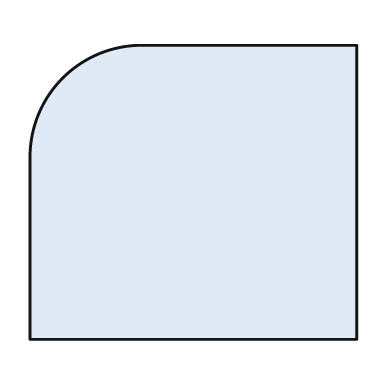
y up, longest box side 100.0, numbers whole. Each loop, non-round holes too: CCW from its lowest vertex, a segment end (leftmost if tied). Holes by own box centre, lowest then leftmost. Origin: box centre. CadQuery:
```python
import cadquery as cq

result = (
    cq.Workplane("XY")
    .moveTo(-50.0, -45.0)
    .lineTo(50.0, -45.0)
    .lineTo(50.0, 45.0)
    .lineTo(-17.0, 45.0)
    .threePointArc((-40.0, 35.0), (-50.0, 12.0))
    .close()
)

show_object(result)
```